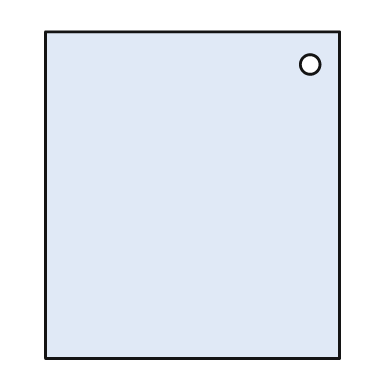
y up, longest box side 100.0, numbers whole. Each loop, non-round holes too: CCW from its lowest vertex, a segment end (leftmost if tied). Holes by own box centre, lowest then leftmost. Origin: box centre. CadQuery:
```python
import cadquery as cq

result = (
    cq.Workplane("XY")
    .moveTo(-45.0, -50.0)
    .lineTo(45.0, -50.0)
    .lineTo(45.0, 50.0)
    .lineTo(-45.0, 50.0)
    .close()
    .moveTo(36.0, 40.0)
    .circle(3.0)
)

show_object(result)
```